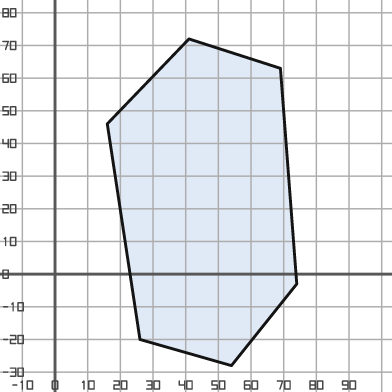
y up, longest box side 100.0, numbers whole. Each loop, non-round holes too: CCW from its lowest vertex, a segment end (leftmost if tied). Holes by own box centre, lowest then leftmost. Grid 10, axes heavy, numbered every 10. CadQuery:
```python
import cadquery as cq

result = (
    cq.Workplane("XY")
    .moveTo(54.0, -28.0)
    .lineTo(74.0, -3.0)
    .lineTo(69.0, 63.0)
    .lineTo(41.0, 72.0)
    .lineTo(16.0, 46.0)
    .lineTo(26.0, -20.0)
    .close()
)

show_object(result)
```